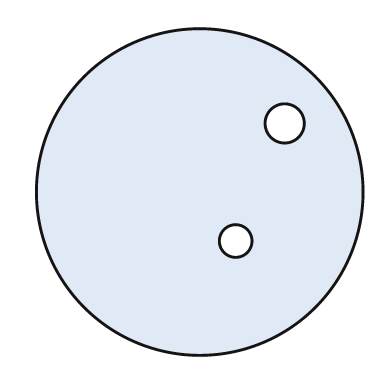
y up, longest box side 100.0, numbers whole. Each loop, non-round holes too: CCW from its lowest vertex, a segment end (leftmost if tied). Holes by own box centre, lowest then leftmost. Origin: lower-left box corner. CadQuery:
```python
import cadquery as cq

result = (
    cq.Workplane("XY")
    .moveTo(50.0, 50.0)
    .circle(50.0)
    .moveTo(61.0, 35.0)
    .circle(5.0)
    .moveTo(76.0, 71.0)
    .circle(6.0)
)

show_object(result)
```